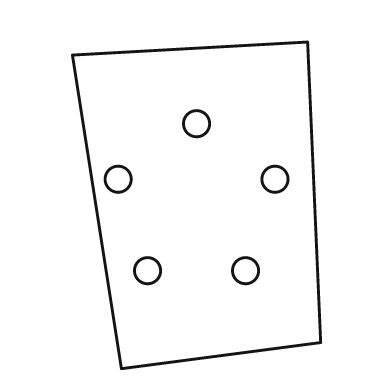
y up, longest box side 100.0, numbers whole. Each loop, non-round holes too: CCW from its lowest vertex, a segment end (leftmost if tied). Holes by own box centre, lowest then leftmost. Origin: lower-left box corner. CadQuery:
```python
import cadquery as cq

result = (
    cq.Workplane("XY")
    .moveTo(15.0, 0.0)
    .lineTo(76.0, 8.0)
    .lineTo(72.0, 100.0)
    .lineTo(0.0, 96.0)
    .close()
    .moveTo(23.0, 30.0)
    .circle(4.0)
    .moveTo(53.0, 30.0)
    .circle(4.0)
    .moveTo(14.0, 58.0)
    .circle(4.0)
    .moveTo(62.0, 58.0)
    .circle(4.0)
    .moveTo(38.0, 75.0)
    .circle(4.0)
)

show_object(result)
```